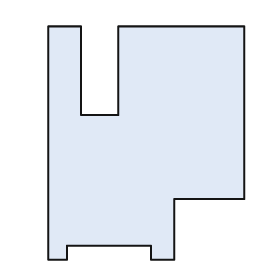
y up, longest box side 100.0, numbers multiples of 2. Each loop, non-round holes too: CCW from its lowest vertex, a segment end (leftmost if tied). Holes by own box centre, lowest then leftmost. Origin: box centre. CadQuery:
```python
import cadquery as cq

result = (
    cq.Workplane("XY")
    .moveTo(-42.0, -50.0)
    .lineTo(-34.0, -50.0)
    .lineTo(-34.0, -44.0)
    .lineTo(2.0, -44.0)
    .lineTo(2.0, -50.0)
    .lineTo(12.0, -50.0)
    .lineTo(12.0, -24.0)
    .lineTo(42.0, -24.0)
    .lineTo(42.0, 50.0)
    .lineTo(-12.0, 50.0)
    .lineTo(-12.0, 12.0)
    .lineTo(-28.0, 12.0)
    .lineTo(-28.0, 50.0)
    .lineTo(-42.0, 50.0)
    .close()
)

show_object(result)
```